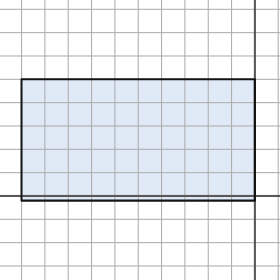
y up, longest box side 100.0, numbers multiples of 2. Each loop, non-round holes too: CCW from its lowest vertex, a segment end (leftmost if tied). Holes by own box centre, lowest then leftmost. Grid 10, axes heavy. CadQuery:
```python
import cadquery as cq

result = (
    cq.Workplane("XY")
    .moveTo(-100.0, -2.0)
    .lineTo(0.0, -2.0)
    .lineTo(0.0, 50.0)
    .lineTo(-100.0, 50.0)
    .close()
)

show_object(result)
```